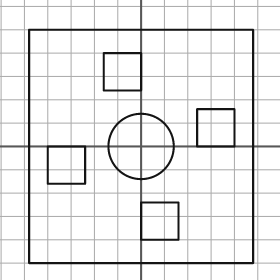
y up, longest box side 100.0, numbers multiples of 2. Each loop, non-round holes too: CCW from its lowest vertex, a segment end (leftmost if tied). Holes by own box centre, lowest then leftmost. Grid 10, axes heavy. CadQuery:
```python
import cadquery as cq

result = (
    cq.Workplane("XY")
    .moveTo(-48.0, -50.0)
    .lineTo(48.0, -50.0)
    .lineTo(48.0, 50.0)
    .lineTo(-48.0, 50.0)
    .close()
    .moveTo(0.0, -40.0)
    .lineTo(16.0, -40.0)
    .lineTo(16.0, -24.0)
    .lineTo(0.0, -24.0)
    .close()
    .moveTo(-40.0, -16.0)
    .lineTo(-24.0, -16.0)
    .lineTo(-24.0, 0.0)
    .lineTo(-40.0, 0.0)
    .close()
    .moveTo(0.0, 0.0)
    .circle(14.0)
    .moveTo(24.0, 0.0)
    .lineTo(40.0, 0.0)
    .lineTo(40.0, 16.0)
    .lineTo(24.0, 16.0)
    .close()
    .moveTo(-16.0, 24.0)
    .lineTo(0.0, 24.0)
    .lineTo(0.0, 40.0)
    .lineTo(-16.0, 40.0)
    .close()
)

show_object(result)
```